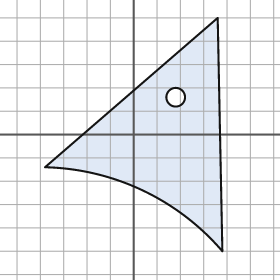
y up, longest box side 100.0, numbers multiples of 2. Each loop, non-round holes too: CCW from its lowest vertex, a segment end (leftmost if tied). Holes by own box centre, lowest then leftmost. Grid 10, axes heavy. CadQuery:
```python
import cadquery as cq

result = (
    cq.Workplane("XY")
    .moveTo(38.0, -50.0)
    .lineTo(36.0, 50.0)
    .lineTo(-38.0, -14.0)
    .threePointArc((4.0, -24.0), (38.0, -50.0))
    .close()
    .moveTo(18.0, 16.0)
    .circle(4.0)
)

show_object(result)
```